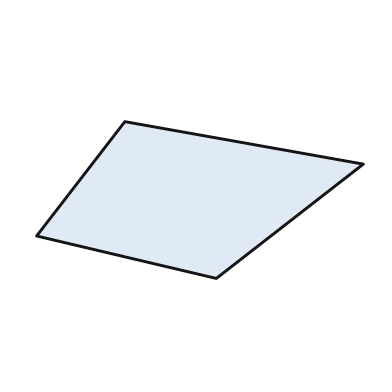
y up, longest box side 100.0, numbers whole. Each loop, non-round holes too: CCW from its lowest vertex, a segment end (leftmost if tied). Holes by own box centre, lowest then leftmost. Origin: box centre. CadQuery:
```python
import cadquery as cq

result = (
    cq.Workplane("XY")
    .moveTo(5.0, -24.0)
    .lineTo(50.0, 11.0)
    .lineTo(-23.0, 24.0)
    .lineTo(-50.0, -11.0)
    .close()
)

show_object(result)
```